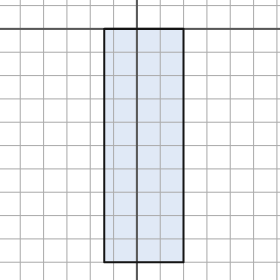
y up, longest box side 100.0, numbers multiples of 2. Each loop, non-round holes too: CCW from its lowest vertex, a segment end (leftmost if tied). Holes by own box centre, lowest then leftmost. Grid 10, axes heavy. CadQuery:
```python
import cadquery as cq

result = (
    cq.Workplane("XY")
    .moveTo(-14.0, -100.0)
    .lineTo(20.0, -100.0)
    .lineTo(20.0, 0.0)
    .lineTo(-14.0, 0.0)
    .close()
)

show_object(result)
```